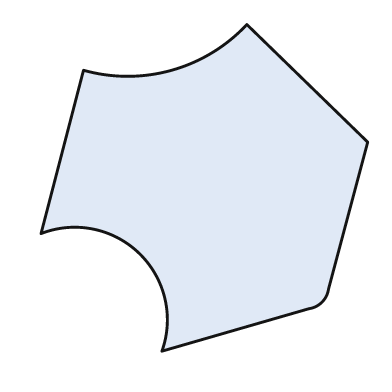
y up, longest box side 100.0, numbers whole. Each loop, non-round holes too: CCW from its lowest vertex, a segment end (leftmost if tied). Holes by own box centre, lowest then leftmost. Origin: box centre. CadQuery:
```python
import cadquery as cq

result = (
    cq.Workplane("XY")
    .moveTo(-13.0, -50.0)
    .lineTo(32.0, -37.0)
    .threePointArc((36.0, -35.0), (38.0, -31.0))
    .lineTo(50.0, 14.0)
    .lineTo(13.0, 50.0)
    .threePointArc((-10.0, 36.0), (-37.0, 36.0))
    .lineTo(-50.0, -14.0)
    .threePointArc((-20.0, -20.0), (-13.0, -50.0))
    .close()
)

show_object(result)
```